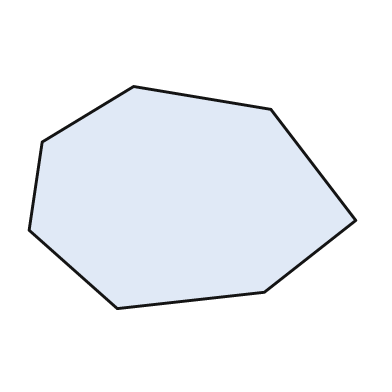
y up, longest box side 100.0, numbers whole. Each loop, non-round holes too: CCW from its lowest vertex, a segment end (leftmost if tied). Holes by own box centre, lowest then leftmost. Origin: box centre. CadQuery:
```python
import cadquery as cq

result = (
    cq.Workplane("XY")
    .moveTo(-23.0, -34.0)
    .lineTo(22.0, -29.0)
    .lineTo(50.0, -7.0)
    .lineTo(24.0, 27.0)
    .lineTo(-18.0, 34.0)
    .lineTo(-46.0, 17.0)
    .lineTo(-50.0, -10.0)
    .close()
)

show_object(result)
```